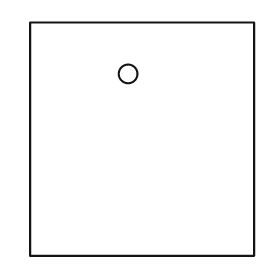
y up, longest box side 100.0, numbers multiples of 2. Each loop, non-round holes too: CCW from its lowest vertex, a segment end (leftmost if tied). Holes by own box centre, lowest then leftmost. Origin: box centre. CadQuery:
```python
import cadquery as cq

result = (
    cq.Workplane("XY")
    .moveTo(-48.0, -50.0)
    .lineTo(48.0, -50.0)
    .lineTo(48.0, 50.0)
    .lineTo(-48.0, 50.0)
    .close()
    .moveTo(-6.0, 28.0)
    .circle(4.0)
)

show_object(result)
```